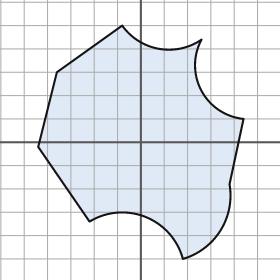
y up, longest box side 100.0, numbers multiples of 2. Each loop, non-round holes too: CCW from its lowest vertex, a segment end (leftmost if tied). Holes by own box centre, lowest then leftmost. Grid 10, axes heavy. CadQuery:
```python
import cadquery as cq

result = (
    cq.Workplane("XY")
    .moveTo(18.0, -50.0)
    .threePointArc((34.0, -38.0), (38.0, -18.0))
    .lineTo(44.0, 10.0)
    .threePointArc((26.0, 22.0), (26.0, 44.0))
    .threePointArc((8.0, 40.0), (-8.0, 50.0))
    .lineTo(-36.0, 30.0)
    .lineTo(-44.0, -2.0)
    .lineTo(-22.0, -34.0)
    .threePointArc((2.0, -32.0), (18.0, -50.0))
    .close()
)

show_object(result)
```